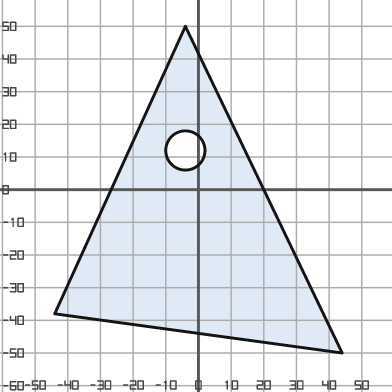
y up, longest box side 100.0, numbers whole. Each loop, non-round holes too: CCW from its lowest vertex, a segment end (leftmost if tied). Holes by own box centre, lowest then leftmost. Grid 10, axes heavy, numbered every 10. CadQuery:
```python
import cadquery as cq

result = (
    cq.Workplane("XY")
    .moveTo(44.0, -50.0)
    .lineTo(-4.0, 50.0)
    .lineTo(-44.0, -38.0)
    .close()
    .moveTo(-4.0, 12.0)
    .circle(6.0)
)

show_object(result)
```